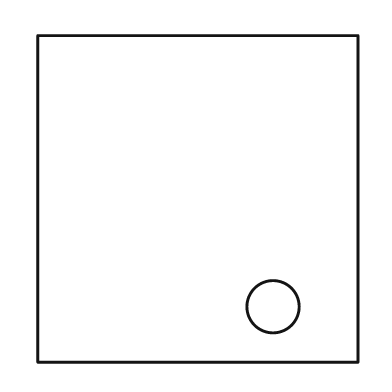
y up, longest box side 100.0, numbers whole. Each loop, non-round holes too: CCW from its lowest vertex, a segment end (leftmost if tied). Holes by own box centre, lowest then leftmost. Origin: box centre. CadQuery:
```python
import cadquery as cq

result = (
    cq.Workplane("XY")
    .moveTo(-49.0, -50.0)
    .lineTo(49.0, -50.0)
    .lineTo(49.0, 50.0)
    .lineTo(-49.0, 50.0)
    .close()
    .moveTo(23.0, -33.0)
    .circle(8.0)
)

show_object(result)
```